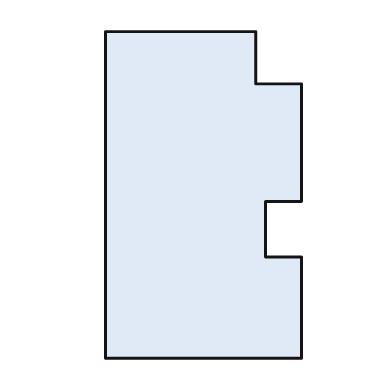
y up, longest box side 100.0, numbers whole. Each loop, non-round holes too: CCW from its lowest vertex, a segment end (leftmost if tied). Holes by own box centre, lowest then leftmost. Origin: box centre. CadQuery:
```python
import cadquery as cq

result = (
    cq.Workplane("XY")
    .moveTo(-30.0, -50.0)
    .lineTo(30.0, -50.0)
    .lineTo(30.0, -19.0)
    .lineTo(19.0, -19.0)
    .lineTo(19.0, -2.0)
    .lineTo(30.0, -2.0)
    .lineTo(30.0, 34.0)
    .lineTo(16.0, 34.0)
    .lineTo(16.0, 50.0)
    .lineTo(-30.0, 50.0)
    .close()
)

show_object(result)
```